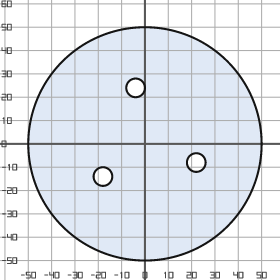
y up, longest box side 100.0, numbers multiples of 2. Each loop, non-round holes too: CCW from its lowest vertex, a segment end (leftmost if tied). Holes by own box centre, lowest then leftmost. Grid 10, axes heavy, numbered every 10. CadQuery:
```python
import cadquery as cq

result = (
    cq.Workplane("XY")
    .moveTo(0.0, 0.0)
    .circle(50.0)
    .moveTo(-18.0, -14.0)
    .circle(4.0)
    .moveTo(22.0, -8.0)
    .circle(4.0)
    .moveTo(-4.0, 24.0)
    .circle(4.0)
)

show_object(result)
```